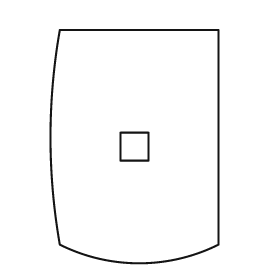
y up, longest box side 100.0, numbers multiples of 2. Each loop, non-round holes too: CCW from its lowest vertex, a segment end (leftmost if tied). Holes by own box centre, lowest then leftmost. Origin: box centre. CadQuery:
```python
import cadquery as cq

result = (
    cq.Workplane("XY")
    .moveTo(-32.0, -42.0)
    .threePointArc((2.0, -50.0), (36.0, -42.0))
    .lineTo(36.0, 50.0)
    .lineTo(-32.0, 50.0)
    .threePointArc((-36.0, 4.0), (-32.0, -42.0))
    .close()
    .moveTo(-6.0, -6.0)
    .lineTo(6.0, -6.0)
    .lineTo(6.0, 6.0)
    .lineTo(-6.0, 6.0)
    .close()
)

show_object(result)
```